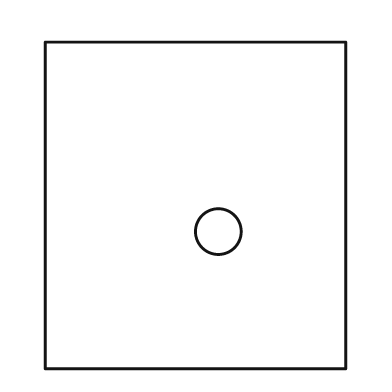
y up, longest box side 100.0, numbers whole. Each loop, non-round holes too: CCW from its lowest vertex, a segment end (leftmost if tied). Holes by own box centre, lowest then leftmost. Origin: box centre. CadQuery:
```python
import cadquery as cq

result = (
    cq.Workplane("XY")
    .moveTo(-46.0, -50.0)
    .lineTo(46.0, -50.0)
    .lineTo(46.0, 50.0)
    .lineTo(-46.0, 50.0)
    .close()
    .moveTo(7.0, -8.0)
    .circle(7.0)
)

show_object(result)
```